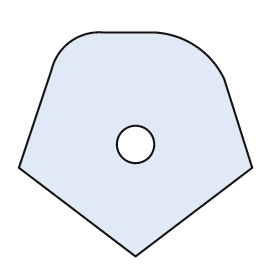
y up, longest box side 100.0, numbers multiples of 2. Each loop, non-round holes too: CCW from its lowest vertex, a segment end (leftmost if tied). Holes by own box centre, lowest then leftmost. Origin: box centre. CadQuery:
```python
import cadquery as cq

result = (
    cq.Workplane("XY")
    .moveTo(0.0, -48.0)
    .lineTo(50.0, -10.0)
    .lineTo(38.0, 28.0)
    .threePointArc((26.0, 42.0), (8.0, 48.0))
    .lineTo(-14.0, 48.0)
    .threePointArc((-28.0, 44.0), (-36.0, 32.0))
    .lineTo(-50.0, -10.0)
    .close()
    .moveTo(0.0, 0.0)
    .circle(8.0)
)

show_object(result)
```